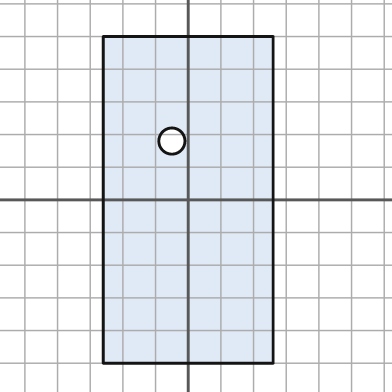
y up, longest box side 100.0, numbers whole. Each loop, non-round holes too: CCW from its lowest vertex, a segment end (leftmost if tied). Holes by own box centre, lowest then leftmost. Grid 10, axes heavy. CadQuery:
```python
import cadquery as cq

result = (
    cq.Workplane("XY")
    .moveTo(-26.0, -50.0)
    .lineTo(26.0, -50.0)
    .lineTo(26.0, 50.0)
    .lineTo(-26.0, 50.0)
    .close()
    .moveTo(-5.0, 18.0)
    .circle(4.0)
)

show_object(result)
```